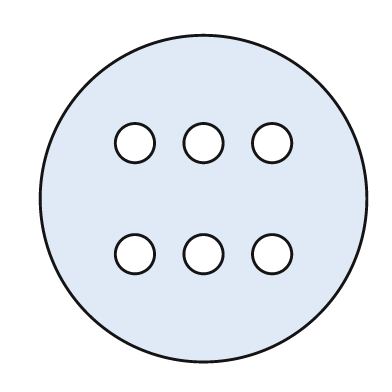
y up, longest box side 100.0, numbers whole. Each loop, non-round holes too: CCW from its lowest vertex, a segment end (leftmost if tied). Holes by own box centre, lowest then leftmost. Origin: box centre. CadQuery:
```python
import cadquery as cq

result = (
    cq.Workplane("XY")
    .moveTo(0.0, 0.0)
    .circle(50.0)
    .moveTo(-21.0, -17.0)
    .circle(6.0)
    .moveTo(0.0, -17.0)
    .circle(6.0)
    .moveTo(21.0, -17.0)
    .circle(6.0)
    .moveTo(-21.0, 17.0)
    .circle(6.0)
    .moveTo(0.0, 17.0)
    .circle(6.0)
    .moveTo(21.0, 17.0)
    .circle(6.0)
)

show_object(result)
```